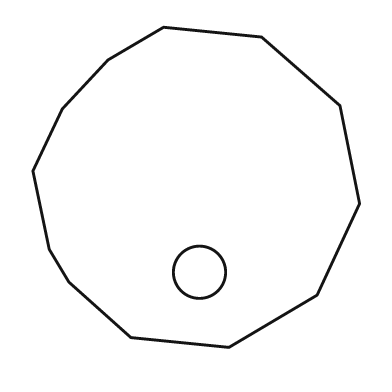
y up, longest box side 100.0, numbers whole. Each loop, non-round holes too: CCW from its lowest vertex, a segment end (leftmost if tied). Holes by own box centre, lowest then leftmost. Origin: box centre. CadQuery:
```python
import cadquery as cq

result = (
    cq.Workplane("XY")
    .moveTo(10.0, -49.0)
    .lineTo(37.0, -33.0)
    .lineTo(50.0, -5.0)
    .lineTo(44.0, 25.0)
    .lineTo(20.0, 46.0)
    .lineTo(-10.0, 49.0)
    .lineTo(-27.0, 39.0)
    .lineTo(-41.0, 24.0)
    .lineTo(-50.0, 5.0)
    .lineTo(-45.0, -19.0)
    .lineTo(-39.0, -29.0)
    .lineTo(-20.0, -46.0)
    .close()
    .moveTo(1.0, -26.0)
    .circle(8.0)
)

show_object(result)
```